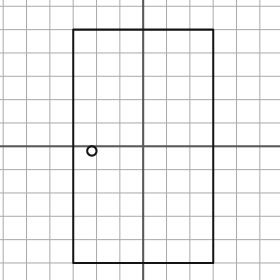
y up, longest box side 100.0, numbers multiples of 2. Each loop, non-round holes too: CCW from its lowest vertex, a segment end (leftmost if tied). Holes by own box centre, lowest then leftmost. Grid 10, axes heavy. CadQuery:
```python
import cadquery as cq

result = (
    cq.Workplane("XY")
    .moveTo(-30.0, -50.0)
    .lineTo(30.0, -50.0)
    .lineTo(30.0, 50.0)
    .lineTo(-30.0, 50.0)
    .close()
    .moveTo(-22.0, -2.0)
    .circle(2.0)
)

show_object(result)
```